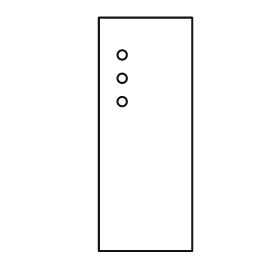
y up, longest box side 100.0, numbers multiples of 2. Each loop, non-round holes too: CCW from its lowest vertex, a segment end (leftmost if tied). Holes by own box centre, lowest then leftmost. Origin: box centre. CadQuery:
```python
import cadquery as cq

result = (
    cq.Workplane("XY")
    .moveTo(-20.0, -50.0)
    .lineTo(20.0, -50.0)
    .lineTo(20.0, 50.0)
    .lineTo(-20.0, 50.0)
    .close()
    .moveTo(-10.0, 14.0)
    .circle(2.0)
    .moveTo(-10.0, 24.0)
    .circle(2.0)
    .moveTo(-10.0, 34.0)
    .circle(2.0)
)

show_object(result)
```